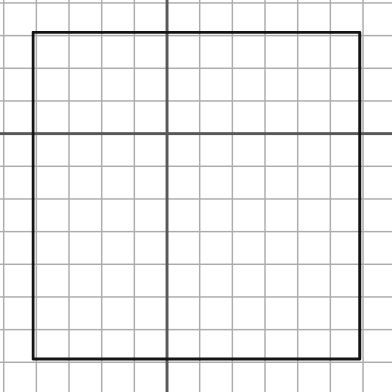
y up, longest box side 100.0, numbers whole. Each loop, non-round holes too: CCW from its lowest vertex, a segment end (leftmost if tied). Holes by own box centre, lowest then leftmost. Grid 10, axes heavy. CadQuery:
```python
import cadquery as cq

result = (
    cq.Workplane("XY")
    .moveTo(-41.0, -69.0)
    .lineTo(59.0, -69.0)
    .lineTo(59.0, 31.0)
    .lineTo(-41.0, 31.0)
    .close()
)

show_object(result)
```